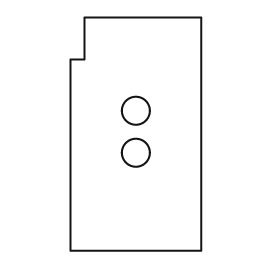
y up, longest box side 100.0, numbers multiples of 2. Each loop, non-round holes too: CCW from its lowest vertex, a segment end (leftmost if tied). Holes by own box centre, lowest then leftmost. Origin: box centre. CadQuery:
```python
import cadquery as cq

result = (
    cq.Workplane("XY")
    .moveTo(-28.0, -50.0)
    .lineTo(28.0, -50.0)
    .lineTo(28.0, 50.0)
    .lineTo(-22.0, 50.0)
    .lineTo(-22.0, 32.0)
    .lineTo(-28.0, 32.0)
    .close()
    .moveTo(0.0, -8.0)
    .circle(6.0)
    .moveTo(0.0, 10.0)
    .circle(6.0)
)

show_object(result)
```